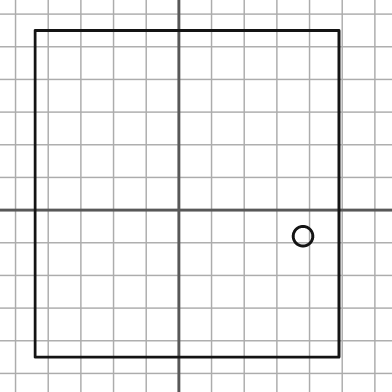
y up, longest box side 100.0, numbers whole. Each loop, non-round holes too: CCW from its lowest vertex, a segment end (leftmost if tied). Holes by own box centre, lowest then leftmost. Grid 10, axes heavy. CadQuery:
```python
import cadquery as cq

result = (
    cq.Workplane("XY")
    .moveTo(-44.0, -45.0)
    .lineTo(49.0, -45.0)
    .lineTo(49.0, 55.0)
    .lineTo(-44.0, 55.0)
    .close()
    .moveTo(38.0, -8.0)
    .circle(3.0)
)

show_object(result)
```